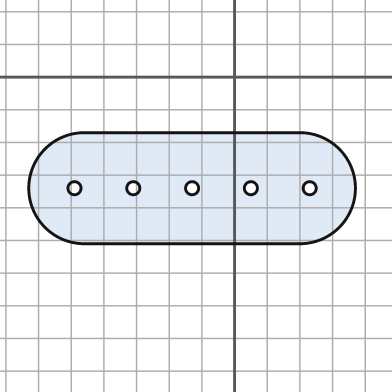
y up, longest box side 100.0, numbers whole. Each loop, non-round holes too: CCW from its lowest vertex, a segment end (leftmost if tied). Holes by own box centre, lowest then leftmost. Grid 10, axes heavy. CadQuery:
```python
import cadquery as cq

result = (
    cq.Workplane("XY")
    .moveTo(-46.0, -51.0)
    .lineTo(20.0, -51.0)
    .threePointArc((37.0, -34.0), (20.0, -17.0))
    .lineTo(-46.0, -17.0)
    .threePointArc((-63.0, -34.0), (-46.0, -51.0))
    .close()
    .moveTo(-49.0, -34.0)
    .circle(2.0)
    .moveTo(-31.0, -34.0)
    .circle(2.0)
    .moveTo(-13.0, -34.0)
    .circle(2.0)
    .moveTo(5.0, -34.0)
    .circle(2.0)
    .moveTo(23.0, -34.0)
    .circle(2.0)
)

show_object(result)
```